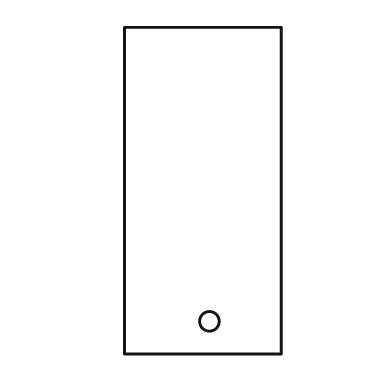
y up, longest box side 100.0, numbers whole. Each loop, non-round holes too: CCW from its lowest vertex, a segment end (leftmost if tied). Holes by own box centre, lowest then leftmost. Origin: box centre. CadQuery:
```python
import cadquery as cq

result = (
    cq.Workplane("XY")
    .moveTo(-24.0, -50.0)
    .lineTo(24.0, -50.0)
    .lineTo(24.0, 50.0)
    .lineTo(-24.0, 50.0)
    .close()
    .moveTo(2.0, -40.0)
    .circle(3.0)
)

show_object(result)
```